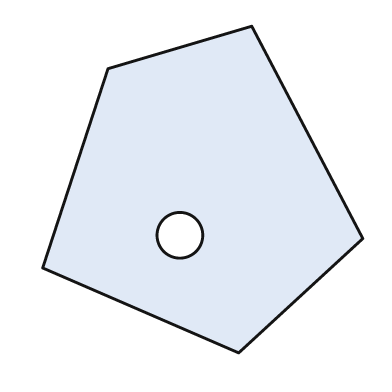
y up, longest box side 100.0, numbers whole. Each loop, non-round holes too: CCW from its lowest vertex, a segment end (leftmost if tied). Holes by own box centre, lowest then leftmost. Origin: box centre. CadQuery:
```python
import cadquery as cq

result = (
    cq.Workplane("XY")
    .moveTo(11.0, -50.0)
    .lineTo(49.0, -15.0)
    .lineTo(15.0, 50.0)
    .lineTo(-29.0, 37.0)
    .lineTo(-49.0, -24.0)
    .close()
    .moveTo(-7.0, -14.0)
    .circle(7.0)
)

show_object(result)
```